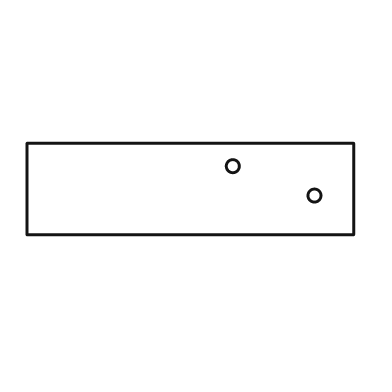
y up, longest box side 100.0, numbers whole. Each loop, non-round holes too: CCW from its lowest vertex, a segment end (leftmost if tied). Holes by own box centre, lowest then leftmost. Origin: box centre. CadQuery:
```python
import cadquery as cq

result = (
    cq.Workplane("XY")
    .moveTo(-50.0, -14.0)
    .lineTo(50.0, -14.0)
    .lineTo(50.0, 14.0)
    .lineTo(-50.0, 14.0)
    .close()
    .moveTo(38.0, -2.0)
    .circle(2.0)
    .moveTo(13.0, 7.0)
    .circle(2.0)
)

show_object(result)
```